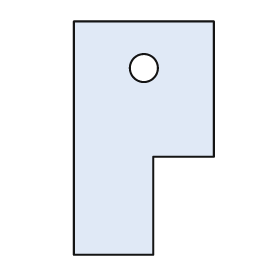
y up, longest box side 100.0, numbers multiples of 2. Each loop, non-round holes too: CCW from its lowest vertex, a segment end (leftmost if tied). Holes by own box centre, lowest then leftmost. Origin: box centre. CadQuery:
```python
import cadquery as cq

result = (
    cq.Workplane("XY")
    .moveTo(-30.0, -50.0)
    .lineTo(4.0, -50.0)
    .lineTo(4.0, -8.0)
    .lineTo(30.0, -8.0)
    .lineTo(30.0, 50.0)
    .lineTo(-30.0, 50.0)
    .close()
    .moveTo(0.0, 30.0)
    .circle(6.0)
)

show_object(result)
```